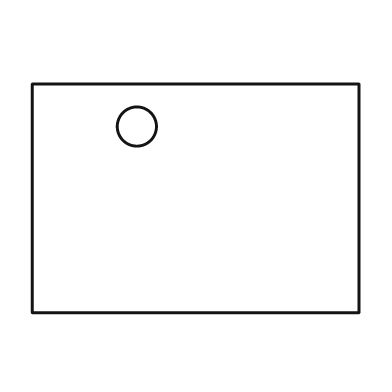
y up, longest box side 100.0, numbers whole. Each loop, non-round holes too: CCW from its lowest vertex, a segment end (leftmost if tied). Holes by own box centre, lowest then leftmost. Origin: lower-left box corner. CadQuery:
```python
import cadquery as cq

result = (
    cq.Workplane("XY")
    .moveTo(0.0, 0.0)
    .lineTo(100.0, 0.0)
    .lineTo(100.0, 70.0)
    .lineTo(0.0, 70.0)
    .close()
    .moveTo(32.0, 57.0)
    .circle(6.0)
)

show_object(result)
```